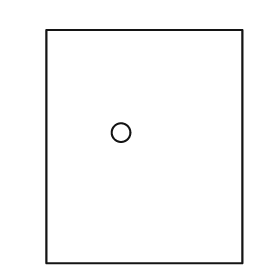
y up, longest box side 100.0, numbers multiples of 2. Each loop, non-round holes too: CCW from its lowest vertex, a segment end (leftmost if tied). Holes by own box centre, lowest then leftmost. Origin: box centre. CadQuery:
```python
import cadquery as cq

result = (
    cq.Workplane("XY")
    .moveTo(-42.0, -50.0)
    .lineTo(42.0, -50.0)
    .lineTo(42.0, 50.0)
    .lineTo(-42.0, 50.0)
    .close()
    .moveTo(-10.0, 6.0)
    .circle(4.0)
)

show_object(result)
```